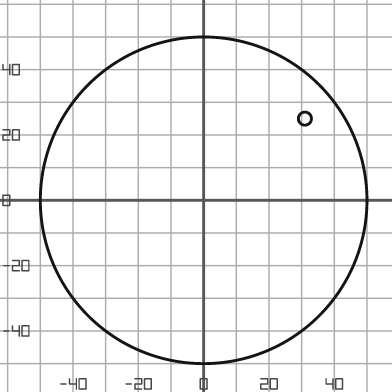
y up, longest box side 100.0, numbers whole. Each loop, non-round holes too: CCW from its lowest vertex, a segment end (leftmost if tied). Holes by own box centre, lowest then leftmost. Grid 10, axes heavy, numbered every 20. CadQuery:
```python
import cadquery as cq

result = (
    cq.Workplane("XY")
    .moveTo(0.0, 0.0)
    .circle(50.0)
    .moveTo(31.0, 25.0)
    .circle(2.0)
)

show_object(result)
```